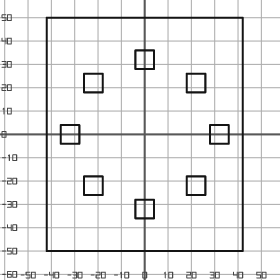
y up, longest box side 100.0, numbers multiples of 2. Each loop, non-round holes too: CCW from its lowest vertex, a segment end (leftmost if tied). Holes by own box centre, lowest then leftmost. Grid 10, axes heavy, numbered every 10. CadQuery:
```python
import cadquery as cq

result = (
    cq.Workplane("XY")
    .moveTo(-42.0, -50.0)
    .lineTo(42.0, -50.0)
    .lineTo(42.0, 50.0)
    .lineTo(-42.0, 50.0)
    .close()
    .moveTo(-4.0, -36.0)
    .lineTo(4.0, -36.0)
    .lineTo(4.0, -28.0)
    .lineTo(-4.0, -28.0)
    .close()
    .moveTo(-26.0, -26.0)
    .lineTo(-18.0, -26.0)
    .lineTo(-18.0, -18.0)
    .lineTo(-26.0, -18.0)
    .close()
    .moveTo(18.0, -26.0)
    .lineTo(26.0, -26.0)
    .lineTo(26.0, -18.0)
    .lineTo(18.0, -18.0)
    .close()
    .moveTo(-36.0, -4.0)
    .lineTo(-28.0, -4.0)
    .lineTo(-28.0, 4.0)
    .lineTo(-36.0, 4.0)
    .close()
    .moveTo(28.0, -4.0)
    .lineTo(36.0, -4.0)
    .lineTo(36.0, 4.0)
    .lineTo(28.0, 4.0)
    .close()
    .moveTo(-26.0, 18.0)
    .lineTo(-18.0, 18.0)
    .lineTo(-18.0, 26.0)
    .lineTo(-26.0, 26.0)
    .close()
    .moveTo(18.0, 18.0)
    .lineTo(26.0, 18.0)
    .lineTo(26.0, 26.0)
    .lineTo(18.0, 26.0)
    .close()
    .moveTo(-4.0, 28.0)
    .lineTo(4.0, 28.0)
    .lineTo(4.0, 36.0)
    .lineTo(-4.0, 36.0)
    .close()
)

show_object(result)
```